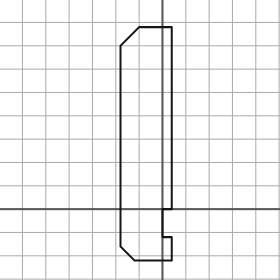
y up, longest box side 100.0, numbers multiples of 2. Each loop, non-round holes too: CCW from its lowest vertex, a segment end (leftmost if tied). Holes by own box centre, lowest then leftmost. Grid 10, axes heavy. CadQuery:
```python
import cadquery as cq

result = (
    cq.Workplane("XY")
    .moveTo(-12.0, -22.0)
    .lineTo(4.0, -22.0)
    .lineTo(4.0, -12.0)
    .lineTo(0.0, -12.0)
    .lineTo(0.0, 0.0)
    .lineTo(4.0, 0.0)
    .lineTo(4.0, 78.0)
    .lineTo(-10.0, 78.0)
    .lineTo(-18.0, 70.0)
    .lineTo(-18.0, -16.0)
    .close()
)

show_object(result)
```